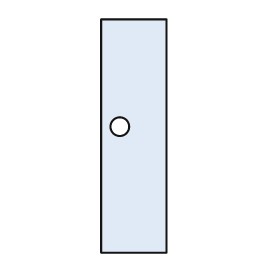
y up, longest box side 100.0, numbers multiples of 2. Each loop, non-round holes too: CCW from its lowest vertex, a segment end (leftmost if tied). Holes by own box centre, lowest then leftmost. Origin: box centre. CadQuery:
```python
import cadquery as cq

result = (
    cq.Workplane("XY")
    .moveTo(-14.0, -50.0)
    .lineTo(14.0, -50.0)
    .lineTo(14.0, 50.0)
    .lineTo(-14.0, 50.0)
    .close()
    .moveTo(-6.0, 4.0)
    .circle(4.0)
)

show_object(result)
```